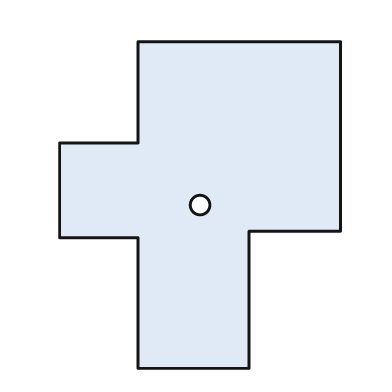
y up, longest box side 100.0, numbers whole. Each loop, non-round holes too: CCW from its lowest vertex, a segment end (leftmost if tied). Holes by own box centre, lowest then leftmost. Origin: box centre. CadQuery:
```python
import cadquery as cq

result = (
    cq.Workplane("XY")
    .moveTo(-19.0, -50.0)
    .lineTo(15.0, -50.0)
    .lineTo(15.0, -8.0)
    .lineTo(43.0, -8.0)
    .lineTo(43.0, 50.0)
    .lineTo(-19.0, 50.0)
    .lineTo(-19.0, 19.0)
    .lineTo(-43.0, 19.0)
    .lineTo(-43.0, -10.0)
    .lineTo(-19.0, -10.0)
    .close()
    .moveTo(0.0, 0.0)
    .circle(3.0)
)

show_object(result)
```